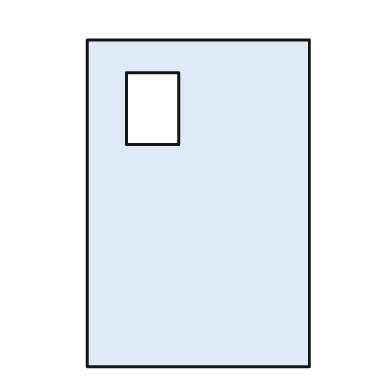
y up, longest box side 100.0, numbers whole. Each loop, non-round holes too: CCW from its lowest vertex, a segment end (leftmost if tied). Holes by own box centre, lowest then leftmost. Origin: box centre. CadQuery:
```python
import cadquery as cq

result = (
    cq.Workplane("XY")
    .moveTo(-34.0, -50.0)
    .lineTo(34.0, -50.0)
    .lineTo(34.0, 50.0)
    .lineTo(-34.0, 50.0)
    .close()
    .moveTo(-22.0, 18.0)
    .lineTo(-6.0, 18.0)
    .lineTo(-6.0, 40.0)
    .lineTo(-22.0, 40.0)
    .close()
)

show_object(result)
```